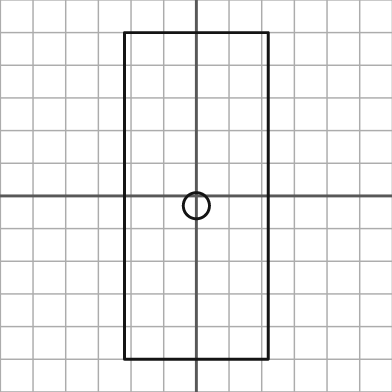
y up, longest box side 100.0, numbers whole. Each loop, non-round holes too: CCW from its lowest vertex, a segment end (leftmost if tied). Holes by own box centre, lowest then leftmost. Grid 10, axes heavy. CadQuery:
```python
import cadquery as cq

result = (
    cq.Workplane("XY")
    .moveTo(-22.0, -50.0)
    .lineTo(22.0, -50.0)
    .lineTo(22.0, 50.0)
    .lineTo(-22.0, 50.0)
    .close()
    .moveTo(0.0, -3.0)
    .circle(4.0)
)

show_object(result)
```